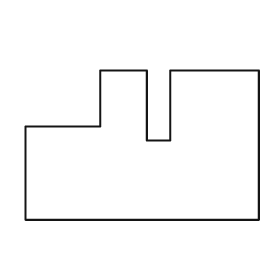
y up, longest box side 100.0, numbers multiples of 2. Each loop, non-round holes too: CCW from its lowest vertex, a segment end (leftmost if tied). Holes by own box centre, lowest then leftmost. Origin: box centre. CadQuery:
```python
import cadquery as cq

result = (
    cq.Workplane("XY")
    .moveTo(-50.0, -32.0)
    .lineTo(50.0, -32.0)
    .lineTo(50.0, 32.0)
    .lineTo(12.0, 32.0)
    .lineTo(12.0, 2.0)
    .lineTo(2.0, 2.0)
    .lineTo(2.0, 32.0)
    .lineTo(-18.0, 32.0)
    .lineTo(-18.0, 8.0)
    .lineTo(-50.0, 8.0)
    .close()
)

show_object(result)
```